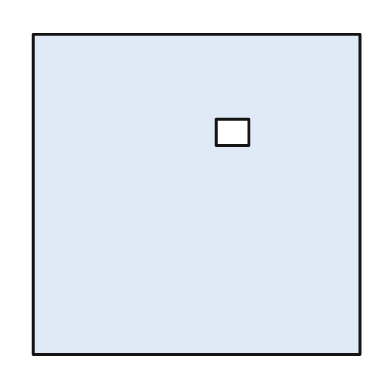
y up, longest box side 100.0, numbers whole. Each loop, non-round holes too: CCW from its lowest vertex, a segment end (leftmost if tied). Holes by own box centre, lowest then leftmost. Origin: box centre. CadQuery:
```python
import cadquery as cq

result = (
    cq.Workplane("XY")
    .moveTo(-50.0, -49.0)
    .lineTo(50.0, -49.0)
    .lineTo(50.0, 49.0)
    .lineTo(-50.0, 49.0)
    .close()
    .moveTo(6.0, 15.0)
    .lineTo(16.0, 15.0)
    .lineTo(16.0, 23.0)
    .lineTo(6.0, 23.0)
    .close()
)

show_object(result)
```